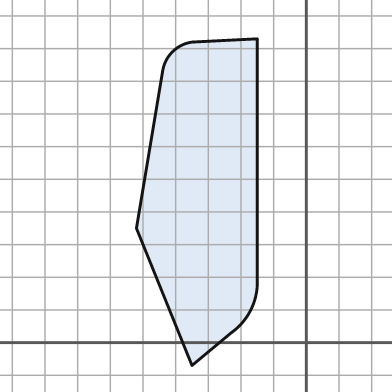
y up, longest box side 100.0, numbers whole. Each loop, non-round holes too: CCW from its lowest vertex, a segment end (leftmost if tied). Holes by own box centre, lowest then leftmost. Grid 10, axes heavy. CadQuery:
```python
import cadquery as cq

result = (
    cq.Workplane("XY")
    .moveTo(-35.0, -7.0)
    .lineTo(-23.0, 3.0)
    .threePointArc((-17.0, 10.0), (-15.0, 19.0))
    .lineTo(-15.0, 93.0)
    .lineTo(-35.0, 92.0)
    .threePointArc((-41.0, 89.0), (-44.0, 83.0))
    .lineTo(-52.0, 35.0)
    .close()
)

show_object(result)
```